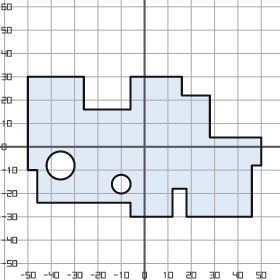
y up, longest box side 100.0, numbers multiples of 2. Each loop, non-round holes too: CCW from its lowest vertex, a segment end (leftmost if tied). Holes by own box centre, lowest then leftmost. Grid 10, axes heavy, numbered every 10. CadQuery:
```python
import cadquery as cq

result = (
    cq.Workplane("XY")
    .moveTo(-6.0, -30.0)
    .lineTo(12.0, -30.0)
    .lineTo(12.0, -18.0)
    .lineTo(18.0, -18.0)
    .lineTo(18.0, -30.0)
    .lineTo(46.0, -30.0)
    .lineTo(46.0, -8.0)
    .lineTo(50.0, -8.0)
    .lineTo(50.0, 4.0)
    .lineTo(28.0, 4.0)
    .lineTo(28.0, 22.0)
    .lineTo(16.0, 22.0)
    .lineTo(16.0, 30.0)
    .lineTo(-6.0, 30.0)
    .lineTo(-6.0, 16.0)
    .lineTo(-26.0, 16.0)
    .lineTo(-26.0, 30.0)
    .lineTo(-50.0, 30.0)
    .lineTo(-50.0, -10.0)
    .lineTo(-46.0, -10.0)
    .lineTo(-46.0, -24.0)
    .lineTo(-6.0, -24.0)
    .close()
    .moveTo(-10.0, -16.0)
    .circle(4.0)
    .moveTo(-36.0, -8.0)
    .circle(6.0)
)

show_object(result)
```